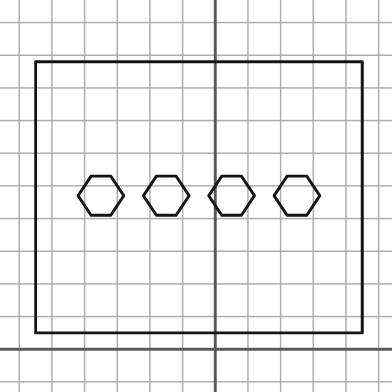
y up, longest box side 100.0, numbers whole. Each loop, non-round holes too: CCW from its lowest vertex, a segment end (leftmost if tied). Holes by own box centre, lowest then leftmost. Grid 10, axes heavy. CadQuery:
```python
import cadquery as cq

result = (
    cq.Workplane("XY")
    .moveTo(-55.0, 5.0)
    .lineTo(45.0, 5.0)
    .lineTo(45.0, 88.0)
    .lineTo(-55.0, 88.0)
    .close()
    .moveTo(-38.0, 41.0)
    .lineTo(-32.0, 41.0)
    .lineTo(-28.0, 47.0)
    .lineTo(-32.0, 53.0)
    .lineTo(-38.0, 53.0)
    .lineTo(-42.0, 47.0)
    .close()
    .moveTo(-18.0, 41.0)
    .lineTo(-12.0, 41.0)
    .lineTo(-8.0, 47.0)
    .lineTo(-12.0, 53.0)
    .lineTo(-18.0, 53.0)
    .lineTo(-22.0, 47.0)
    .close()
    .moveTo(2.0, 41.0)
    .lineTo(8.0, 41.0)
    .lineTo(12.0, 47.0)
    .lineTo(8.0, 53.0)
    .lineTo(2.0, 53.0)
    .lineTo(-2.0, 47.0)
    .close()
    .moveTo(22.0, 41.0)
    .lineTo(28.0, 41.0)
    .lineTo(32.0, 47.0)
    .lineTo(28.0, 53.0)
    .lineTo(22.0, 53.0)
    .lineTo(18.0, 47.0)
    .close()
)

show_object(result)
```